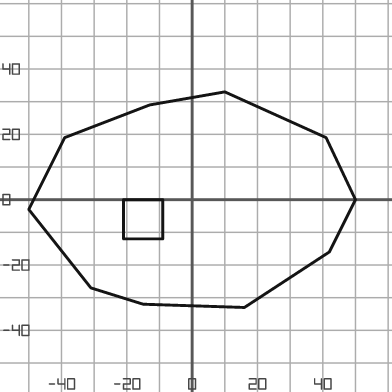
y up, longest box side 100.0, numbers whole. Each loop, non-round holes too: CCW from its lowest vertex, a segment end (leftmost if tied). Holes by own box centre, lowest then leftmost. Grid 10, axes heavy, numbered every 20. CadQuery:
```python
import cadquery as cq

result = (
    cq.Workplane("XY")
    .moveTo(16.0, -33.0)
    .lineTo(42.0, -16.0)
    .lineTo(50.0, 0.0)
    .lineTo(41.0, 19.0)
    .lineTo(10.0, 33.0)
    .lineTo(-13.0, 29.0)
    .lineTo(-39.0, 19.0)
    .lineTo(-50.0, -3.0)
    .lineTo(-31.0, -27.0)
    .lineTo(-15.0, -32.0)
    .close()
    .moveTo(-21.0, -12.0)
    .lineTo(-9.0, -12.0)
    .lineTo(-9.0, 0.0)
    .lineTo(-21.0, 0.0)
    .close()
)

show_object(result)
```